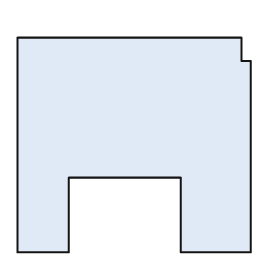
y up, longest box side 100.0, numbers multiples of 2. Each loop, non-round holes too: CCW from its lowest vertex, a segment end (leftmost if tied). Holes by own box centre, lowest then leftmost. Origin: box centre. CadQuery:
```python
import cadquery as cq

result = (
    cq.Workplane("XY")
    .moveTo(-50.0, -46.0)
    .lineTo(-28.0, -46.0)
    .lineTo(-28.0, -14.0)
    .lineTo(20.0, -14.0)
    .lineTo(20.0, -46.0)
    .lineTo(50.0, -46.0)
    .lineTo(50.0, 36.0)
    .lineTo(46.0, 36.0)
    .lineTo(46.0, 46.0)
    .lineTo(-50.0, 46.0)
    .close()
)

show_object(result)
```